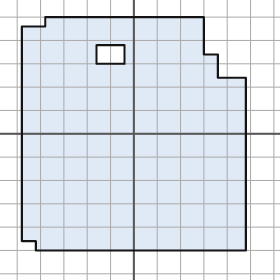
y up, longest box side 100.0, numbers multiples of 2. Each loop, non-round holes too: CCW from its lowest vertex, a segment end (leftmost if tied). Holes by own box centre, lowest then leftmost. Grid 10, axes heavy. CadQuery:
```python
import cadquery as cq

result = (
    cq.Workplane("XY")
    .moveTo(-42.0, -50.0)
    .lineTo(48.0, -50.0)
    .lineTo(48.0, 24.0)
    .lineTo(36.0, 24.0)
    .lineTo(36.0, 34.0)
    .lineTo(30.0, 34.0)
    .lineTo(30.0, 50.0)
    .lineTo(-38.0, 50.0)
    .lineTo(-38.0, 46.0)
    .lineTo(-48.0, 46.0)
    .lineTo(-48.0, -46.0)
    .lineTo(-42.0, -46.0)
    .close()
    .moveTo(-16.0, 30.0)
    .lineTo(-4.0, 30.0)
    .lineTo(-4.0, 38.0)
    .lineTo(-16.0, 38.0)
    .close()
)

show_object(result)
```